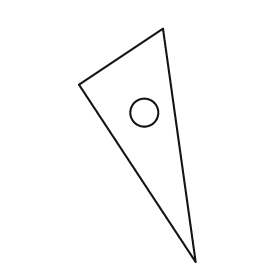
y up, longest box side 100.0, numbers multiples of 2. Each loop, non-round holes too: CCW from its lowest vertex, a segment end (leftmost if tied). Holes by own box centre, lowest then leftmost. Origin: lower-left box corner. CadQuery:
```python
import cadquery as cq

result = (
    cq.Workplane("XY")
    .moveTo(50.0, 0.0)
    .lineTo(36.0, 100.0)
    .lineTo(0.0, 76.0)
    .close()
    .moveTo(28.0, 64.0)
    .circle(6.0)
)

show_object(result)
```